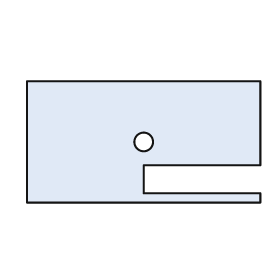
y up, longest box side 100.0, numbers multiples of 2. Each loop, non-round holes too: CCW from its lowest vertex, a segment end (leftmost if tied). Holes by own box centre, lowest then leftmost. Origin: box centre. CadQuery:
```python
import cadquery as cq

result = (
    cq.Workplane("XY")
    .moveTo(-50.0, -26.0)
    .lineTo(50.0, -26.0)
    .lineTo(50.0, -22.0)
    .lineTo(0.0, -22.0)
    .lineTo(0.0, -10.0)
    .lineTo(50.0, -10.0)
    .lineTo(50.0, 26.0)
    .lineTo(-50.0, 26.0)
    .close()
    .moveTo(0.0, 0.0)
    .circle(4.0)
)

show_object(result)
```